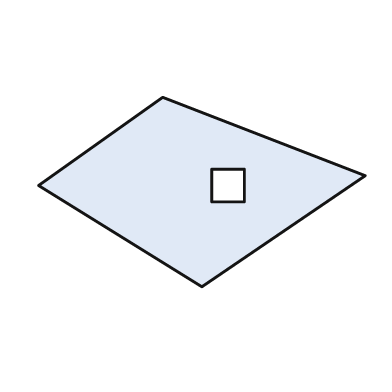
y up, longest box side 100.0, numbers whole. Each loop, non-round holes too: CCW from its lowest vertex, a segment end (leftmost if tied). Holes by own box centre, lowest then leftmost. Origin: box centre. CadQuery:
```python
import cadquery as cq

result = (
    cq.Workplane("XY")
    .moveTo(0.0, -29.0)
    .lineTo(50.0, 5.0)
    .lineTo(-12.0, 29.0)
    .lineTo(-50.0, 2.0)
    .close()
    .moveTo(3.0, -3.0)
    .lineTo(13.0, -3.0)
    .lineTo(13.0, 7.0)
    .lineTo(3.0, 7.0)
    .close()
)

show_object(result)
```